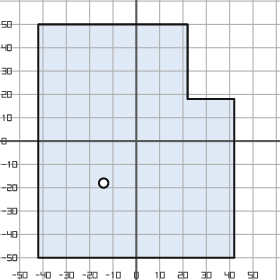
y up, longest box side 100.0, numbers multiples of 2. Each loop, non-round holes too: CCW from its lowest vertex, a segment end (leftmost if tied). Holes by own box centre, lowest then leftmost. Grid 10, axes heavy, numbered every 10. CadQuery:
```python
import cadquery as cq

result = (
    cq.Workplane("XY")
    .moveTo(-42.0, -50.0)
    .lineTo(42.0, -50.0)
    .lineTo(42.0, 18.0)
    .lineTo(22.0, 18.0)
    .lineTo(22.0, 50.0)
    .lineTo(-42.0, 50.0)
    .close()
    .moveTo(-14.0, -18.0)
    .circle(2.0)
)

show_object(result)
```